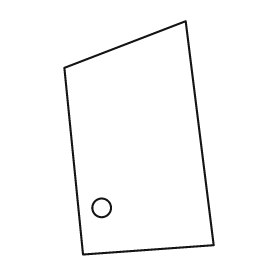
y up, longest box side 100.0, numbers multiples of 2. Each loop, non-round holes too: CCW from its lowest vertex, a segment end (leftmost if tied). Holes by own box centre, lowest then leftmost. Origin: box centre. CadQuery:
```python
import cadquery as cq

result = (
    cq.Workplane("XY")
    .moveTo(-24.0, -50.0)
    .lineTo(32.0, -46.0)
    .lineTo(20.0, 50.0)
    .lineTo(-32.0, 30.0)
    .close()
    .moveTo(-16.0, -30.0)
    .circle(4.0)
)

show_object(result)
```